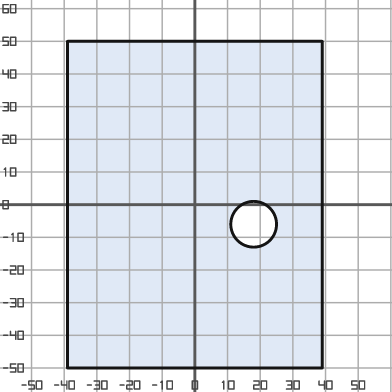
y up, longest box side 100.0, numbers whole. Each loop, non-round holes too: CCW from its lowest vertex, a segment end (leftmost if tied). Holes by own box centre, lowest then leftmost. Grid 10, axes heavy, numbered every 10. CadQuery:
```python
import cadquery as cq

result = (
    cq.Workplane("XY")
    .moveTo(-39.0, -50.0)
    .lineTo(39.0, -50.0)
    .lineTo(39.0, 50.0)
    .lineTo(-39.0, 50.0)
    .close()
    .moveTo(18.0, -6.0)
    .circle(7.0)
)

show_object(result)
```